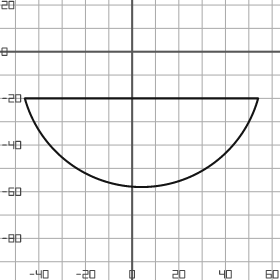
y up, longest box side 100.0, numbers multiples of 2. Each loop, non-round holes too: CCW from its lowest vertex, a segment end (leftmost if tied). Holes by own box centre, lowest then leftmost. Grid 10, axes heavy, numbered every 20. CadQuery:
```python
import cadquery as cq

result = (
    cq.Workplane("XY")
    .moveTo(-46.0, -20.0)
    .threePointArc((4.0, -58.0), (54.0, -20.0))
    .close()
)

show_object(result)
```